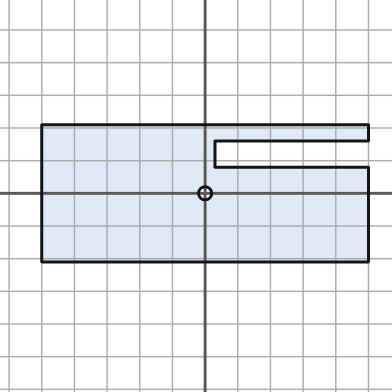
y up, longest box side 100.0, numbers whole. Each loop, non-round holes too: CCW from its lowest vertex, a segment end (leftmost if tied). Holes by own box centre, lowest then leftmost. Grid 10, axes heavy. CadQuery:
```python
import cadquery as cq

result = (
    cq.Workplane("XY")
    .moveTo(-50.0, -21.0)
    .lineTo(50.0, -21.0)
    .lineTo(50.0, 8.0)
    .lineTo(3.0, 8.0)
    .lineTo(3.0, 16.0)
    .lineTo(50.0, 16.0)
    .lineTo(50.0, 21.0)
    .lineTo(-50.0, 21.0)
    .close()
    .moveTo(0.0, 0.0)
    .circle(2.0)
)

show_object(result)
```